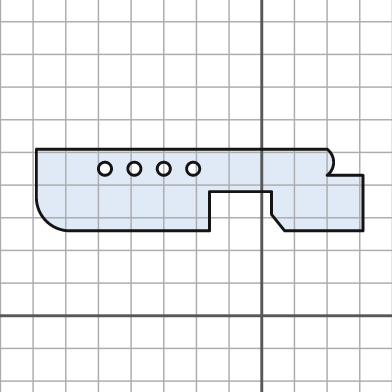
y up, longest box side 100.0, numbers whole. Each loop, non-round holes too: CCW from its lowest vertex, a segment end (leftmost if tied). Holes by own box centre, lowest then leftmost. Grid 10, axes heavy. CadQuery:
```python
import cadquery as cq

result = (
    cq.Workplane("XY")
    .moveTo(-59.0, 26.0)
    .lineTo(-16.0, 26.0)
    .lineTo(-16.0, 38.0)
    .lineTo(3.0, 38.0)
    .lineTo(3.0, 31.0)
    .lineTo(7.0, 26.0)
    .lineTo(31.0, 26.0)
    .lineTo(31.0, 43.0)
    .lineTo(20.0, 43.0)
    .threePointArc((22.0, 47.0), (20.0, 51.0))
    .lineTo(-69.0, 51.0)
    .lineTo(-69.0, 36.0)
    .threePointArc((-66.0, 29.0), (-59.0, 26.0))
    .close()
    .moveTo(-48.0, 45.0)
    .circle(2.0)
    .moveTo(-39.0, 45.0)
    .circle(2.0)
    .moveTo(-30.0, 45.0)
    .circle(2.0)
    .moveTo(-21.0, 45.0)
    .circle(2.0)
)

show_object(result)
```